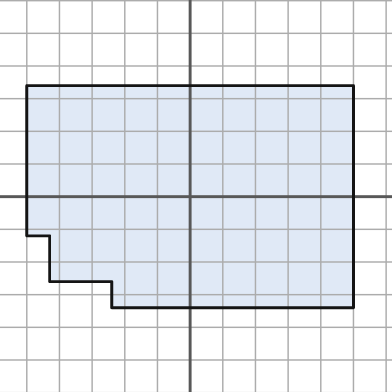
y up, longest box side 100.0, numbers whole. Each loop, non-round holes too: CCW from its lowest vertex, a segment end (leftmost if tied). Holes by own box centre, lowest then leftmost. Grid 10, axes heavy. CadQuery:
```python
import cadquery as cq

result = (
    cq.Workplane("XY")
    .moveTo(-24.0, -34.0)
    .lineTo(50.0, -34.0)
    .lineTo(50.0, 34.0)
    .lineTo(-50.0, 34.0)
    .lineTo(-50.0, -12.0)
    .lineTo(-43.0, -12.0)
    .lineTo(-43.0, -26.0)
    .lineTo(-24.0, -26.0)
    .close()
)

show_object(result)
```